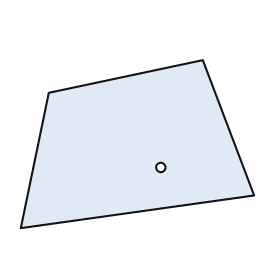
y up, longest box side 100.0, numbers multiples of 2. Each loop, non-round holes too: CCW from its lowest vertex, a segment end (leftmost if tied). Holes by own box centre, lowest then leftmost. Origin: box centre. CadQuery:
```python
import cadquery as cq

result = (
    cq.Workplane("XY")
    .moveTo(-50.0, -36.0)
    .lineTo(50.0, -22.0)
    .lineTo(28.0, 36.0)
    .lineTo(-38.0, 22.0)
    .close()
    .moveTo(10.0, -10.0)
    .circle(2.0)
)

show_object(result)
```